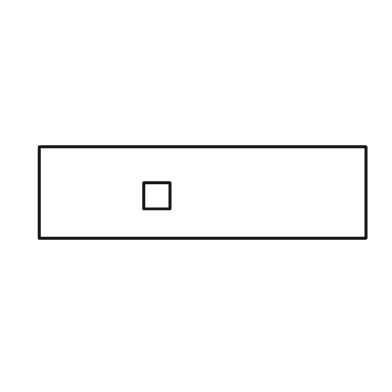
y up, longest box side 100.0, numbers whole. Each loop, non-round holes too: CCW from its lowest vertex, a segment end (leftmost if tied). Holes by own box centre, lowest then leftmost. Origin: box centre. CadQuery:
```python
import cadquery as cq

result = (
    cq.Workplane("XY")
    .moveTo(-50.0, -14.0)
    .lineTo(50.0, -14.0)
    .lineTo(50.0, 14.0)
    .lineTo(-50.0, 14.0)
    .close()
    .moveTo(-18.0, -5.0)
    .lineTo(-10.0, -5.0)
    .lineTo(-10.0, 3.0)
    .lineTo(-18.0, 3.0)
    .close()
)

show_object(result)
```